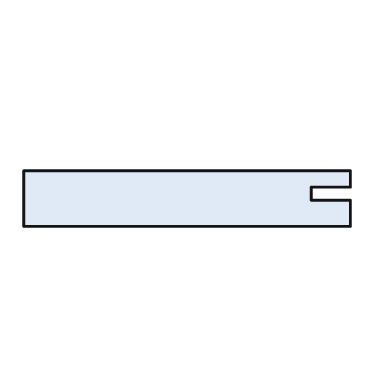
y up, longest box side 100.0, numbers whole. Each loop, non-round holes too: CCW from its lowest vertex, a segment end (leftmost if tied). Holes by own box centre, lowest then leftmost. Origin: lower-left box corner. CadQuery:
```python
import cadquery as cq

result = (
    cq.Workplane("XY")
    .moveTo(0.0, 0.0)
    .lineTo(100.0, 0.0)
    .lineTo(100.0, 8.0)
    .lineTo(88.0, 8.0)
    .lineTo(88.0, 12.0)
    .lineTo(100.0, 12.0)
    .lineTo(100.0, 17.0)
    .lineTo(0.0, 17.0)
    .close()
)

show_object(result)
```